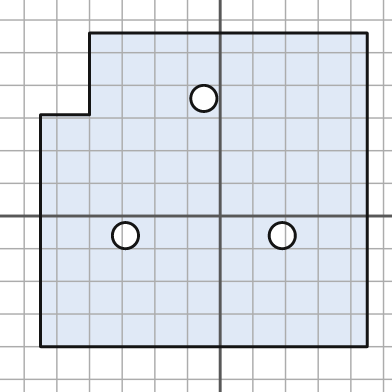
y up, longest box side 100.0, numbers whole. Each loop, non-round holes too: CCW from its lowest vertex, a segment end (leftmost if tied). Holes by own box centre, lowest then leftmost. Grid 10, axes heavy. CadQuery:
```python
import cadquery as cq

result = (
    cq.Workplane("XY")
    .moveTo(-55.0, -40.0)
    .lineTo(45.0, -40.0)
    .lineTo(45.0, 56.0)
    .lineTo(-40.0, 56.0)
    .lineTo(-40.0, 31.0)
    .lineTo(-55.0, 31.0)
    .close()
    .moveTo(-29.0, -6.0)
    .circle(4.0)
    .moveTo(19.0, -6.0)
    .circle(4.0)
    .moveTo(-5.0, 36.0)
    .circle(4.0)
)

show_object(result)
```